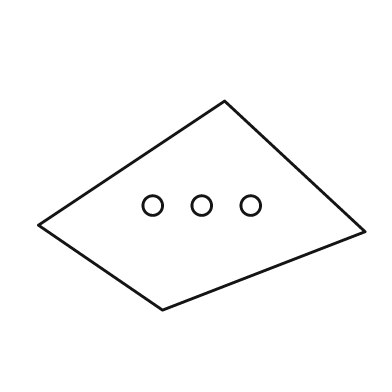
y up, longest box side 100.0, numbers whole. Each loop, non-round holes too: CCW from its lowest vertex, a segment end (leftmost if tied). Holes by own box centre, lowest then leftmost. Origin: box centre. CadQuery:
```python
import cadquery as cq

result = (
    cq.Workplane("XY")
    .moveTo(-12.0, -32.0)
    .lineTo(50.0, -8.0)
    .lineTo(7.0, 32.0)
    .lineTo(-50.0, -6.0)
    .close()
    .moveTo(-15.0, 0.0)
    .circle(3.0)
    .moveTo(0.0, 0.0)
    .circle(3.0)
    .moveTo(15.0, 0.0)
    .circle(3.0)
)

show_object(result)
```